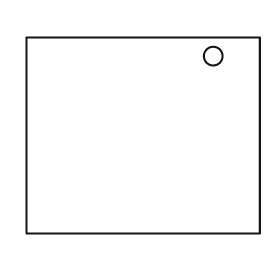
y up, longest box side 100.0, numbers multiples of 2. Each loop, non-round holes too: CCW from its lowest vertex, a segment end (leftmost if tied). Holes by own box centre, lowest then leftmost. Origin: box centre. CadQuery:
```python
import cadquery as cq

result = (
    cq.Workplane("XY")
    .moveTo(-50.0, -42.0)
    .lineTo(50.0, -42.0)
    .lineTo(50.0, 42.0)
    .lineTo(-50.0, 42.0)
    .close()
    .moveTo(30.0, 34.0)
    .circle(4.0)
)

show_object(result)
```